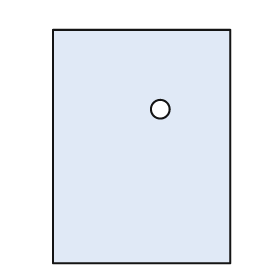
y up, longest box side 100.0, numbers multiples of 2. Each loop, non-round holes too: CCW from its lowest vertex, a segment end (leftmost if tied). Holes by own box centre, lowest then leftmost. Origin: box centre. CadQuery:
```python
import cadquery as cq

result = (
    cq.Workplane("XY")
    .moveTo(-38.0, -50.0)
    .lineTo(38.0, -50.0)
    .lineTo(38.0, 50.0)
    .lineTo(-38.0, 50.0)
    .close()
    .moveTo(8.0, 16.0)
    .circle(4.0)
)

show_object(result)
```